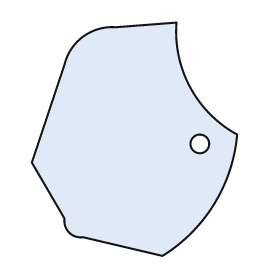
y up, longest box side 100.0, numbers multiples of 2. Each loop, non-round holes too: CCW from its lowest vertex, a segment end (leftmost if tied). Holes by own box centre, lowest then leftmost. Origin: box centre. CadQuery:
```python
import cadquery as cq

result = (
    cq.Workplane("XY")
    .moveTo(12.0, -50.0)
    .threePointArc((34.0, -28.0), (44.0, 2.0))
    .threePointArc((24.0, 22.0), (18.0, 50.0))
    .lineTo(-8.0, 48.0)
    .threePointArc((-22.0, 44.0), (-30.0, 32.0))
    .lineTo(-44.0, -10.0)
    .lineTo(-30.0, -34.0)
    .threePointArc((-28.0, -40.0), (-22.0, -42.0))
    .close()
    .moveTo(28.0, -2.0)
    .circle(4.0)
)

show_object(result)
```